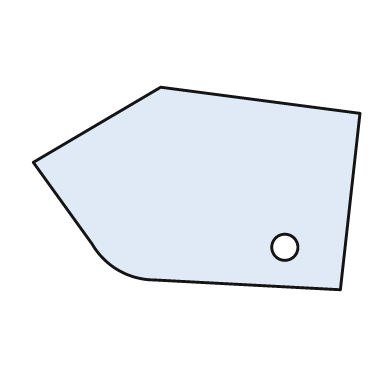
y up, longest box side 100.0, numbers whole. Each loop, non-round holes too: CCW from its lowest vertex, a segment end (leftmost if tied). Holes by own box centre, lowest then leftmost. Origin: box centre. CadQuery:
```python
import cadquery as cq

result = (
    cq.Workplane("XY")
    .moveTo(44.0, -31.0)
    .lineTo(50.0, 23.0)
    .lineTo(-11.0, 31.0)
    .lineTo(-50.0, 8.0)
    .lineTo(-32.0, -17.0)
    .threePointArc((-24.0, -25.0), (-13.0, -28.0))
    .close()
    .moveTo(27.0, -18.0)
    .circle(4.0)
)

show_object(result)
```